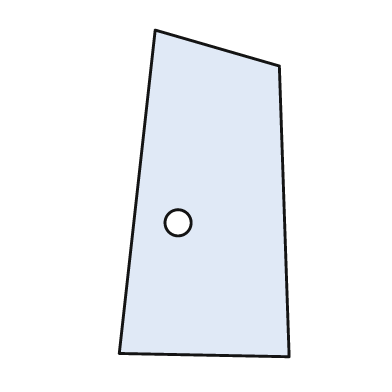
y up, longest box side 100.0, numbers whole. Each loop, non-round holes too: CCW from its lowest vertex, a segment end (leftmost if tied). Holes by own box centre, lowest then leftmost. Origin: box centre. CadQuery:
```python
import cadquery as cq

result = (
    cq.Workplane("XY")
    .moveTo(26.0, -50.0)
    .lineTo(23.0, 39.0)
    .lineTo(-15.0, 50.0)
    .lineTo(-26.0, -49.0)
    .close()
    .moveTo(-8.0, -9.0)
    .circle(4.0)
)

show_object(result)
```